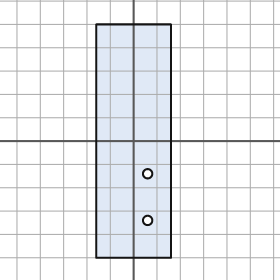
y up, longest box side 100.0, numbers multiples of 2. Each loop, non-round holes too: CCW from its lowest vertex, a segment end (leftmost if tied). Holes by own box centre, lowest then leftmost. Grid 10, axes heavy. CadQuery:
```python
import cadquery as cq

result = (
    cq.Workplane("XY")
    .moveTo(-16.0, -50.0)
    .lineTo(16.0, -50.0)
    .lineTo(16.0, 50.0)
    .lineTo(-16.0, 50.0)
    .close()
    .moveTo(6.0, -34.0)
    .circle(2.0)
    .moveTo(6.0, -14.0)
    .circle(2.0)
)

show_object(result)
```